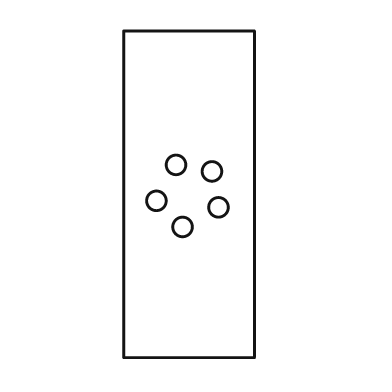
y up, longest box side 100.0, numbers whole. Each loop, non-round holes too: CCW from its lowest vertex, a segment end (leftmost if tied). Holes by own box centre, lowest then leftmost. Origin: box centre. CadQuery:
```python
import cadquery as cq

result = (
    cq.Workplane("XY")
    .moveTo(-20.0, -50.0)
    .lineTo(20.0, -50.0)
    .lineTo(20.0, 50.0)
    .lineTo(-20.0, 50.0)
    .close()
    .moveTo(-2.0, -10.0)
    .circle(3.0)
    .moveTo(9.0, -4.0)
    .circle(3.0)
    .moveTo(-10.0, -2.0)
    .circle(3.0)
    .moveTo(7.0, 7.0)
    .circle(3.0)
    .moveTo(-4.0, 9.0)
    .circle(3.0)
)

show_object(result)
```